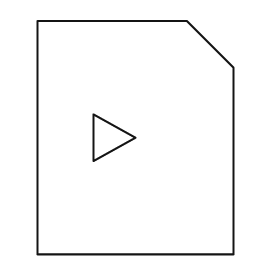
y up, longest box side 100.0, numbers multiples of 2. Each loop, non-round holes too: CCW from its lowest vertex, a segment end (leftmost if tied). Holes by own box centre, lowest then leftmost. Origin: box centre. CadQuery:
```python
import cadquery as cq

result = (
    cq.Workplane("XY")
    .moveTo(-42.0, -50.0)
    .lineTo(42.0, -50.0)
    .lineTo(42.0, 30.0)
    .lineTo(22.0, 50.0)
    .lineTo(-42.0, 50.0)
    .close()
    .moveTo(-18.0, -10.0)
    .lineTo(0.0, 0.0)
    .lineTo(-18.0, 10.0)
    .close()
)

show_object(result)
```